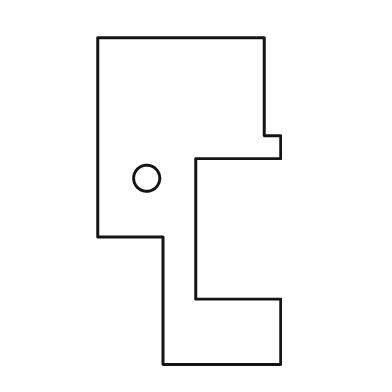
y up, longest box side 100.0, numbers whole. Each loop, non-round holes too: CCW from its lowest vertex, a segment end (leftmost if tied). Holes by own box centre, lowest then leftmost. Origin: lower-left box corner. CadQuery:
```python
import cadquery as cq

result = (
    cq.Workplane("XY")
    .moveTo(20.0, 0.0)
    .lineTo(56.0, 0.0)
    .lineTo(56.0, 20.0)
    .lineTo(30.0, 20.0)
    .lineTo(30.0, 63.0)
    .lineTo(56.0, 63.0)
    .lineTo(56.0, 70.0)
    .lineTo(51.0, 70.0)
    .lineTo(51.0, 100.0)
    .lineTo(0.0, 100.0)
    .lineTo(0.0, 39.0)
    .lineTo(20.0, 39.0)
    .close()
    .moveTo(15.0, 57.0)
    .circle(4.0)
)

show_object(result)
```